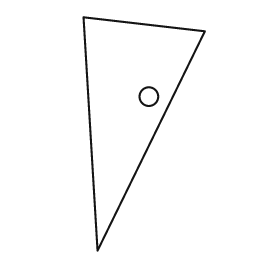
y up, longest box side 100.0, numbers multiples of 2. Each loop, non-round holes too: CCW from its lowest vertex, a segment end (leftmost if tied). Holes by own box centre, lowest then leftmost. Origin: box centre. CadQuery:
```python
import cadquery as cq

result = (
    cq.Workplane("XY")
    .moveTo(-20.0, -50.0)
    .lineTo(26.0, 44.0)
    .lineTo(-26.0, 50.0)
    .close()
    .moveTo(2.0, 16.0)
    .circle(4.0)
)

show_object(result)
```